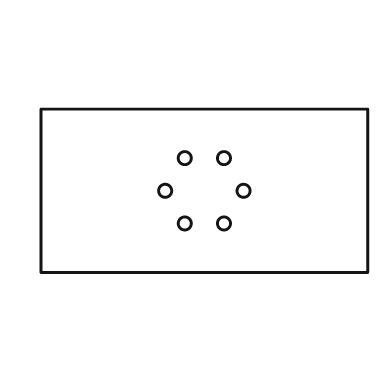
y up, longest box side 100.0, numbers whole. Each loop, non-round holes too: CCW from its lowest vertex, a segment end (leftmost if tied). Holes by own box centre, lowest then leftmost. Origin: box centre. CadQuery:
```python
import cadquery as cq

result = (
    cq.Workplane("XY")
    .moveTo(-50.0, -25.0)
    .lineTo(50.0, -25.0)
    .lineTo(50.0, 25.0)
    .lineTo(-50.0, 25.0)
    .close()
    .moveTo(-6.0, -10.0)
    .circle(2.0)
    .moveTo(6.0, -10.0)
    .circle(2.0)
    .moveTo(-12.0, 0.0)
    .circle(2.0)
    .moveTo(12.0, 0.0)
    .circle(2.0)
    .moveTo(-6.0, 10.0)
    .circle(2.0)
    .moveTo(6.0, 10.0)
    .circle(2.0)
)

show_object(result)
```